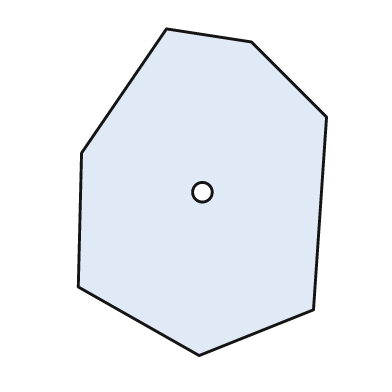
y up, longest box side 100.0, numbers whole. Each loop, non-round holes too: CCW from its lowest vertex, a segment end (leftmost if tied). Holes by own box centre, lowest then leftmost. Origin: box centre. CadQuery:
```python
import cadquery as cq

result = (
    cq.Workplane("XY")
    .moveTo(-1.0, -50.0)
    .lineTo(34.0, -36.0)
    .lineTo(38.0, 23.0)
    .lineTo(15.0, 46.0)
    .lineTo(-11.0, 50.0)
    .lineTo(-37.0, 12.0)
    .lineTo(-38.0, -29.0)
    .close()
    .moveTo(0.0, 0.0)
    .circle(3.0)
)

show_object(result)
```